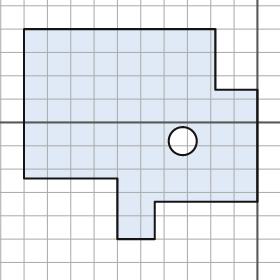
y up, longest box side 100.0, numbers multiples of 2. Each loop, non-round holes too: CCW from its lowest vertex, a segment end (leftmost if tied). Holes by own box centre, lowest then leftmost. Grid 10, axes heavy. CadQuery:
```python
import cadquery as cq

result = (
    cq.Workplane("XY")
    .moveTo(-60.0, -50.0)
    .lineTo(-44.0, -50.0)
    .lineTo(-44.0, -34.0)
    .lineTo(0.0, -34.0)
    .lineTo(0.0, 14.0)
    .lineTo(-18.0, 14.0)
    .lineTo(-18.0, 40.0)
    .lineTo(-100.0, 40.0)
    .lineTo(-100.0, -24.0)
    .lineTo(-60.0, -24.0)
    .close()
    .moveTo(-32.0, -8.0)
    .circle(6.0)
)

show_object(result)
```